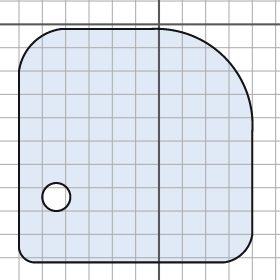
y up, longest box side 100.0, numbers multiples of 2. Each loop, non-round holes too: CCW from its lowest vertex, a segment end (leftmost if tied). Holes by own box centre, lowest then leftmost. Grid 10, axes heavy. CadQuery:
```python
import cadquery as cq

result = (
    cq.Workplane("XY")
    .moveTo(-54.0, -102.0)
    .lineTo(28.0, -102.0)
    .threePointArc((36.0, -98.0), (40.0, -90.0))
    .lineTo(40.0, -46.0)
    .threePointArc((28.0, -14.0), (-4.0, -2.0))
    .lineTo(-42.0, -2.0)
    .threePointArc((-54.0, -8.0), (-60.0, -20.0))
    .lineTo(-60.0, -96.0)
    .threePointArc((-58.0, -100.0), (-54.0, -102.0))
    .close()
    .moveTo(-44.0, -74.0)
    .circle(6.0)
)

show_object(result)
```